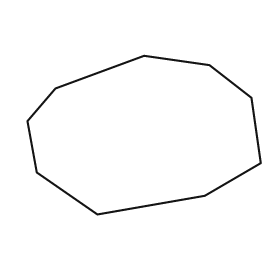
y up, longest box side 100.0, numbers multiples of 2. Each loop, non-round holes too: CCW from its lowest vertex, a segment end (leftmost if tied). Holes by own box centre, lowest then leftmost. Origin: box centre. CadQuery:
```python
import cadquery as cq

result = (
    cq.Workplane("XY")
    .moveTo(-20.0, -34.0)
    .lineTo(26.0, -26.0)
    .lineTo(50.0, -12.0)
    .lineTo(46.0, 16.0)
    .lineTo(28.0, 30.0)
    .lineTo(0.0, 34.0)
    .lineTo(-38.0, 20.0)
    .lineTo(-50.0, 6.0)
    .lineTo(-46.0, -16.0)
    .close()
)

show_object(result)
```